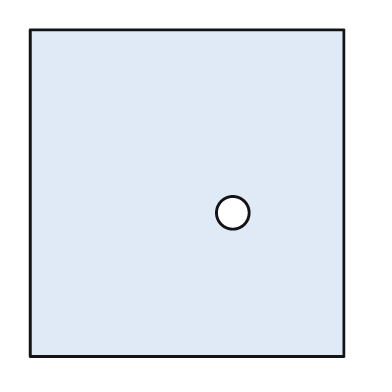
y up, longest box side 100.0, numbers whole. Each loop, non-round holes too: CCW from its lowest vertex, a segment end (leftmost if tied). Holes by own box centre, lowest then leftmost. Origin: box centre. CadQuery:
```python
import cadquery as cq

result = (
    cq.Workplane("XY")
    .moveTo(-48.0, -50.0)
    .lineTo(48.0, -50.0)
    .lineTo(48.0, 50.0)
    .lineTo(-48.0, 50.0)
    .close()
    .moveTo(14.0, -6.0)
    .circle(5.0)
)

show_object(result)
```